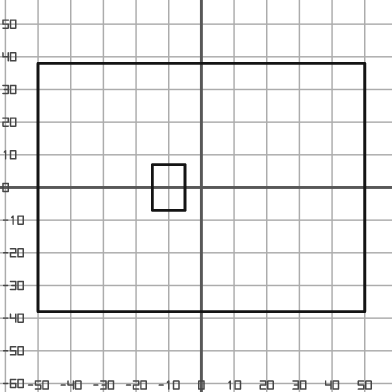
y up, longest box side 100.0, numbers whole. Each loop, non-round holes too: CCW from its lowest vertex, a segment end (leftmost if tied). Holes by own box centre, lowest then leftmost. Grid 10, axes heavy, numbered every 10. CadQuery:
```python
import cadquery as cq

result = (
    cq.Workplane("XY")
    .moveTo(-50.0, -38.0)
    .lineTo(50.0, -38.0)
    .lineTo(50.0, 38.0)
    .lineTo(-50.0, 38.0)
    .close()
    .moveTo(-15.0, -7.0)
    .lineTo(-5.0, -7.0)
    .lineTo(-5.0, 7.0)
    .lineTo(-15.0, 7.0)
    .close()
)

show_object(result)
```